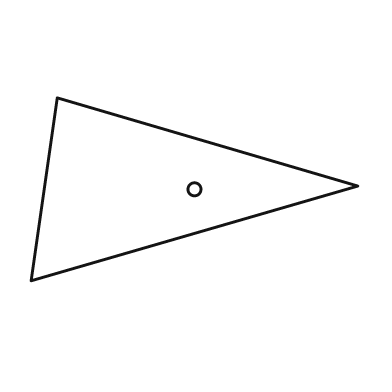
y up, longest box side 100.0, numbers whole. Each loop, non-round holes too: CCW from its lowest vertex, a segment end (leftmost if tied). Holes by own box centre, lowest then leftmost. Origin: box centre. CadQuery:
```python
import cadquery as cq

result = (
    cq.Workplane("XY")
    .moveTo(-50.0, -28.0)
    .lineTo(50.0, 1.0)
    .lineTo(-42.0, 28.0)
    .close()
    .moveTo(0.0, 0.0)
    .circle(2.0)
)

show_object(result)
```